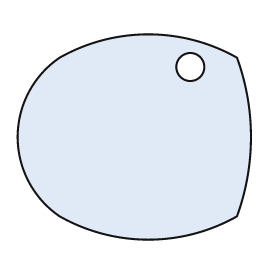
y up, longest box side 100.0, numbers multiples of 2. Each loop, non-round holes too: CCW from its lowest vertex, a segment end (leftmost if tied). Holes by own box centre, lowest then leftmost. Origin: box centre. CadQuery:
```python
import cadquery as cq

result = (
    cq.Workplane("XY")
    .moveTo(-32.0, -34.0)
    .threePointArc((6.0, -44.0), (44.0, -34.0))
    .threePointArc((50.0, 0.0), (44.0, 34.0))
    .threePointArc((6.0, 44.0), (-32.0, 34.0))
    .threePointArc((-50.0, 0.0), (-32.0, -34.0))
    .close()
    .moveTo(24.0, 30.0)
    .circle(6.0)
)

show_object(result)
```